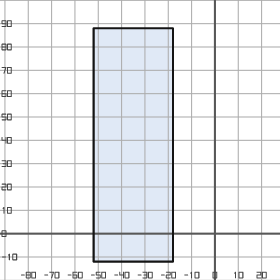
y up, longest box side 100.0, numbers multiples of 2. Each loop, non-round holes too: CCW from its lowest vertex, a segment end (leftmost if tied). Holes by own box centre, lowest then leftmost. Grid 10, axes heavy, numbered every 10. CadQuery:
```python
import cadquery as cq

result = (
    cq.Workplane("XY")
    .moveTo(-52.0, -12.0)
    .lineTo(-18.0, -12.0)
    .lineTo(-18.0, 88.0)
    .lineTo(-52.0, 88.0)
    .close()
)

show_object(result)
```